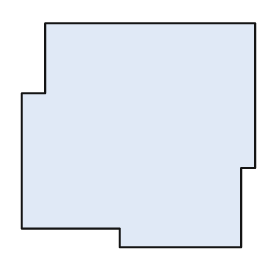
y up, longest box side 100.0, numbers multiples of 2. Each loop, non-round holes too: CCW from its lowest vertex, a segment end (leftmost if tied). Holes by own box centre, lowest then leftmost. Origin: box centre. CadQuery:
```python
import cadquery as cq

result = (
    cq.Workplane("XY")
    .moveTo(-8.0, -48.0)
    .lineTo(44.0, -48.0)
    .lineTo(44.0, -14.0)
    .lineTo(50.0, -14.0)
    .lineTo(50.0, 48.0)
    .lineTo(-40.0, 48.0)
    .lineTo(-40.0, 18.0)
    .lineTo(-50.0, 18.0)
    .lineTo(-50.0, -40.0)
    .lineTo(-8.0, -40.0)
    .close()
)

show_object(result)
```